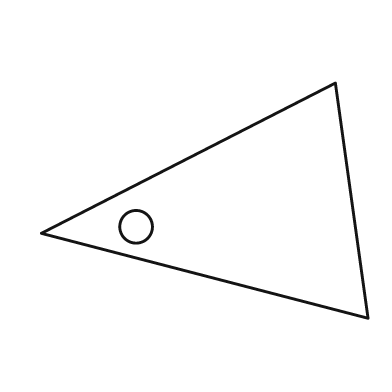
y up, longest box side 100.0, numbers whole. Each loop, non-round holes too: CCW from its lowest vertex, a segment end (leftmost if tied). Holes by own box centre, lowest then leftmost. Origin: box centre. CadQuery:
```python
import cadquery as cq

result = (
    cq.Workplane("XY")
    .moveTo(50.0, -36.0)
    .lineTo(40.0, 36.0)
    .lineTo(-50.0, -10.0)
    .close()
    .moveTo(-21.0, -8.0)
    .circle(5.0)
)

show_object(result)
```